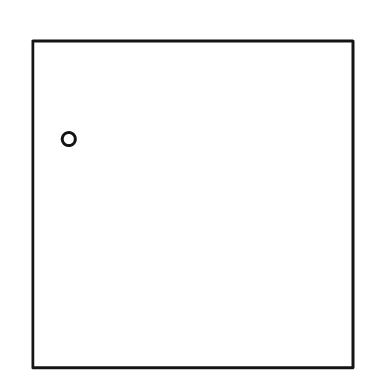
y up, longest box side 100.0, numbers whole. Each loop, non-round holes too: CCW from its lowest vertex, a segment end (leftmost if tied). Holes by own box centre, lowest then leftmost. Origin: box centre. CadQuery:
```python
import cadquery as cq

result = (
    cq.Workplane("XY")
    .moveTo(-49.0, -50.0)
    .lineTo(49.0, -50.0)
    .lineTo(49.0, 50.0)
    .lineTo(-49.0, 50.0)
    .close()
    .moveTo(-38.0, 20.0)
    .circle(2.0)
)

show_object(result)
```